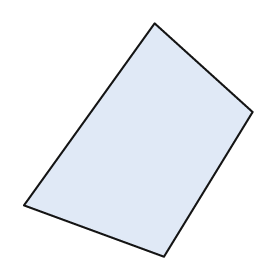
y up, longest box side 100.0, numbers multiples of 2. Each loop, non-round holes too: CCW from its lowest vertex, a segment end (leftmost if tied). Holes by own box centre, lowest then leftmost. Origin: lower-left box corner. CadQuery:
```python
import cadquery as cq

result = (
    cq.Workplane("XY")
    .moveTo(60.0, 0.0)
    .lineTo(98.0, 62.0)
    .lineTo(56.0, 100.0)
    .lineTo(0.0, 22.0)
    .close()
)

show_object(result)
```